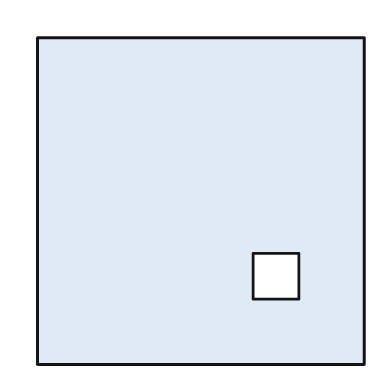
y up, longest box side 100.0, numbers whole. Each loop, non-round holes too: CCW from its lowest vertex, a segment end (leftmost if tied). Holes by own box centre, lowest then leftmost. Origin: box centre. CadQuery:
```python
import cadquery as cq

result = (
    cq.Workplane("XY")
    .moveTo(-50.0, -50.0)
    .lineTo(50.0, -50.0)
    .lineTo(50.0, 50.0)
    .lineTo(-50.0, 50.0)
    .close()
    .moveTo(16.0, -30.0)
    .lineTo(30.0, -30.0)
    .lineTo(30.0, -16.0)
    .lineTo(16.0, -16.0)
    .close()
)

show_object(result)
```